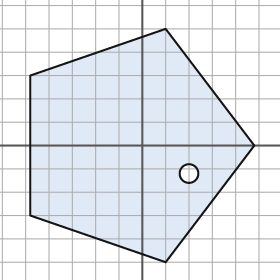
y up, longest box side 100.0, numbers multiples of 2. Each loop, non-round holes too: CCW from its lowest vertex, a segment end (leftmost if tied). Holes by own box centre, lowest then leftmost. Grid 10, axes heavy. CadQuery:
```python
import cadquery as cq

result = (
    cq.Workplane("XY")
    .moveTo(10.0, -50.0)
    .lineTo(48.0, 0.0)
    .lineTo(10.0, 50.0)
    .lineTo(-48.0, 30.0)
    .lineTo(-48.0, -30.0)
    .close()
    .moveTo(20.0, -12.0)
    .circle(4.0)
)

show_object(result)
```